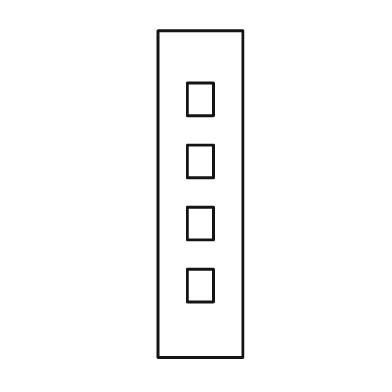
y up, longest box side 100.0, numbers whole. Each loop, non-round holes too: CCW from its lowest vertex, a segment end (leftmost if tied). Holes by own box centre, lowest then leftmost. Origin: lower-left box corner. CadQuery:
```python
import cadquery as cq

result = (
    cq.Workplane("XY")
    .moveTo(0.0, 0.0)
    .lineTo(26.0, 0.0)
    .lineTo(26.0, 100.0)
    .lineTo(0.0, 100.0)
    .close()
    .moveTo(9.0, 17.0)
    .lineTo(17.0, 17.0)
    .lineTo(17.0, 27.0)
    .lineTo(9.0, 27.0)
    .close()
    .moveTo(9.0, 36.0)
    .lineTo(17.0, 36.0)
    .lineTo(17.0, 46.0)
    .lineTo(9.0, 46.0)
    .close()
    .moveTo(9.0, 55.0)
    .lineTo(17.0, 55.0)
    .lineTo(17.0, 65.0)
    .lineTo(9.0, 65.0)
    .close()
    .moveTo(9.0, 74.0)
    .lineTo(17.0, 74.0)
    .lineTo(17.0, 84.0)
    .lineTo(9.0, 84.0)
    .close()
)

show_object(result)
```